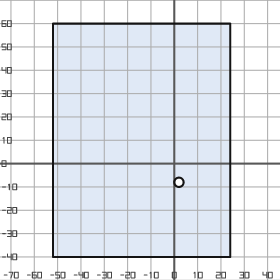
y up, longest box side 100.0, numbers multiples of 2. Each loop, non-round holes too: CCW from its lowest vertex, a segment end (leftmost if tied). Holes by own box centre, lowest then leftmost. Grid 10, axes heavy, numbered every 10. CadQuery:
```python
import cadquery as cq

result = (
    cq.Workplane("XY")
    .moveTo(-52.0, -40.0)
    .lineTo(24.0, -40.0)
    .lineTo(24.0, 60.0)
    .lineTo(-52.0, 60.0)
    .close()
    .moveTo(2.0, -8.0)
    .circle(2.0)
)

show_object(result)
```